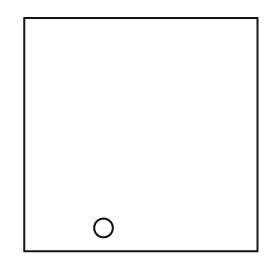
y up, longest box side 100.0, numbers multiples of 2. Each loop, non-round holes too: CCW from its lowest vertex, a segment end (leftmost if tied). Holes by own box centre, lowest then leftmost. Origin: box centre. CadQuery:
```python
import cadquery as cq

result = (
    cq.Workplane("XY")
    .moveTo(-50.0, -50.0)
    .lineTo(50.0, -50.0)
    .lineTo(50.0, 50.0)
    .lineTo(-50.0, 50.0)
    .close()
    .moveTo(-16.0, -40.0)
    .circle(4.0)
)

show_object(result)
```